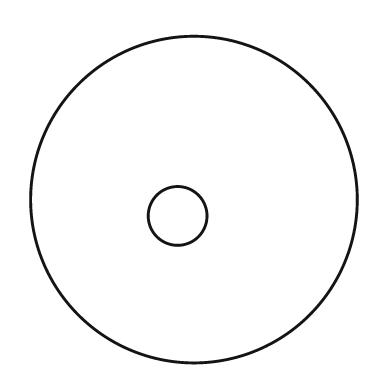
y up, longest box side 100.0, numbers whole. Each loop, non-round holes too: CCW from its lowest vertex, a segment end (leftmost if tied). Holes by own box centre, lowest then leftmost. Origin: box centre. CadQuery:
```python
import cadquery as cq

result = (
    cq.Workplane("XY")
    .moveTo(0.0, 0.0)
    .circle(50.0)
    .moveTo(-5.0, -5.0)
    .circle(9.0)
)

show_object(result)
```